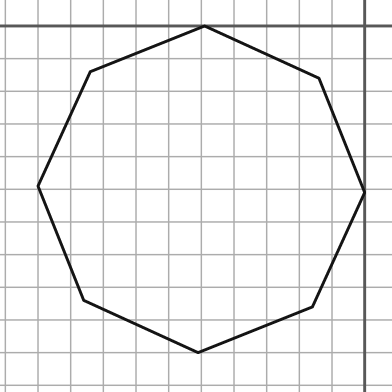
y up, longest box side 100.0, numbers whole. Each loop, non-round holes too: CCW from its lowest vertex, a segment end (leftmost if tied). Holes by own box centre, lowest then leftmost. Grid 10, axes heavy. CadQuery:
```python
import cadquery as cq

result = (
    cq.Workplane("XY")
    .moveTo(-51.0, -100.0)
    .lineTo(-16.0, -86.0)
    .lineTo(0.0, -51.0)
    .lineTo(-14.0, -16.0)
    .lineTo(-49.0, 0.0)
    .lineTo(-84.0, -14.0)
    .lineTo(-100.0, -49.0)
    .lineTo(-86.0, -84.0)
    .close()
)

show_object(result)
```